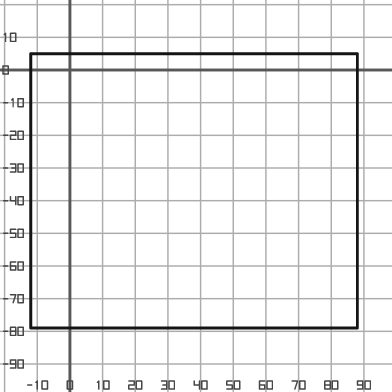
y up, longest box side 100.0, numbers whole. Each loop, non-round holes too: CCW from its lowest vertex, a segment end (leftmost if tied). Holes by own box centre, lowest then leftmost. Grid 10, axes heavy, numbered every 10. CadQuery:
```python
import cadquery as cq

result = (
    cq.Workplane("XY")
    .moveTo(-12.0, -79.0)
    .lineTo(88.0, -79.0)
    .lineTo(88.0, 5.0)
    .lineTo(-12.0, 5.0)
    .close()
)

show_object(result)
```